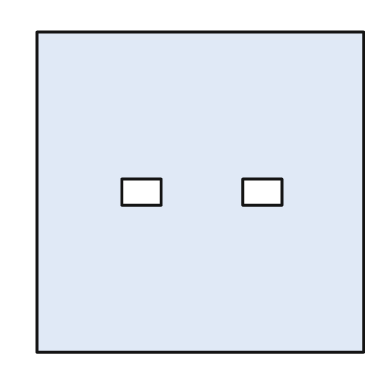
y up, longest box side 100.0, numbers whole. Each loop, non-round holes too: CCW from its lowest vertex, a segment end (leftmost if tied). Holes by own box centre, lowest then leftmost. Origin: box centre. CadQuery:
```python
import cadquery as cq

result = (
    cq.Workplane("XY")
    .moveTo(-50.0, -49.0)
    .lineTo(50.0, -49.0)
    .lineTo(50.0, 49.0)
    .lineTo(-50.0, 49.0)
    .close()
    .moveTo(-24.0, -4.0)
    .lineTo(-12.0, -4.0)
    .lineTo(-12.0, 4.0)
    .lineTo(-24.0, 4.0)
    .close()
    .moveTo(13.0, -4.0)
    .lineTo(25.0, -4.0)
    .lineTo(25.0, 4.0)
    .lineTo(13.0, 4.0)
    .close()
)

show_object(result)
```